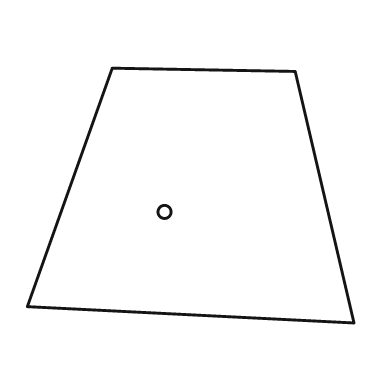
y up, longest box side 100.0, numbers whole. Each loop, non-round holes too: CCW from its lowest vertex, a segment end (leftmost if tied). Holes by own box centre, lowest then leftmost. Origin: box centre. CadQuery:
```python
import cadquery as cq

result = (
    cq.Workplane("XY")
    .moveTo(50.0, -39.0)
    .lineTo(32.0, 38.0)
    .lineTo(-24.0, 39.0)
    .lineTo(-50.0, -34.0)
    .close()
    .moveTo(-8.0, -5.0)
    .circle(2.0)
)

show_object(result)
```